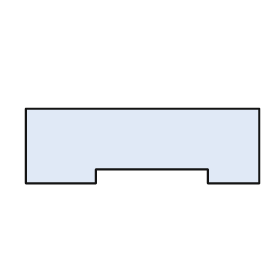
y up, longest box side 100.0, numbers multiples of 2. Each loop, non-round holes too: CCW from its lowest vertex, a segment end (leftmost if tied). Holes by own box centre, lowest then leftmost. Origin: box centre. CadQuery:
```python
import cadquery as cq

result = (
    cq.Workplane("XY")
    .moveTo(-50.0, -16.0)
    .lineTo(-20.0, -16.0)
    .lineTo(-20.0, -10.0)
    .lineTo(28.0, -10.0)
    .lineTo(28.0, -16.0)
    .lineTo(50.0, -16.0)
    .lineTo(50.0, 16.0)
    .lineTo(-50.0, 16.0)
    .close()
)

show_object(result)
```